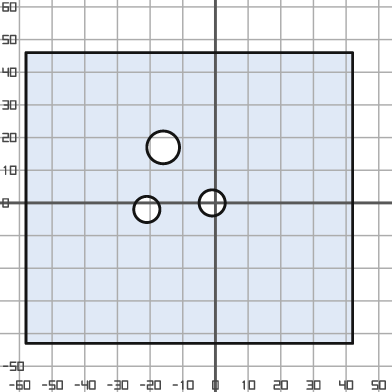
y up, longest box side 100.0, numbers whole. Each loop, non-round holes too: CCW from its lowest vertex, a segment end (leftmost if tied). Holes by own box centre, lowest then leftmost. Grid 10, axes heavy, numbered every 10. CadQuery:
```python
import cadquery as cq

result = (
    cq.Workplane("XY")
    .moveTo(-58.0, -43.0)
    .lineTo(42.0, -43.0)
    .lineTo(42.0, 46.0)
    .lineTo(-58.0, 46.0)
    .close()
    .moveTo(-21.0, -2.0)
    .circle(4.0)
    .moveTo(-1.0, 0.0)
    .circle(4.0)
    .moveTo(-16.0, 17.0)
    .circle(5.0)
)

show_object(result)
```